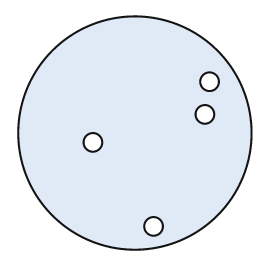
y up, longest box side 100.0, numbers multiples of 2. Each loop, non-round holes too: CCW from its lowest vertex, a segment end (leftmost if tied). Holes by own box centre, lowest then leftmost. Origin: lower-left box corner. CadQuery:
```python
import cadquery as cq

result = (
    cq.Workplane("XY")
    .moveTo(50.0, 50.0)
    .circle(50.0)
    .moveTo(58.0, 10.0)
    .circle(4.0)
    .moveTo(32.0, 46.0)
    .circle(4.0)
    .moveTo(80.0, 58.0)
    .circle(4.0)
    .moveTo(82.0, 72.0)
    .circle(4.0)
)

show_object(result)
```